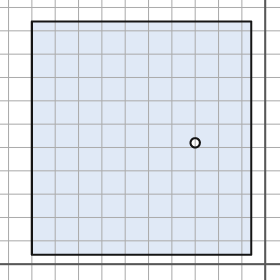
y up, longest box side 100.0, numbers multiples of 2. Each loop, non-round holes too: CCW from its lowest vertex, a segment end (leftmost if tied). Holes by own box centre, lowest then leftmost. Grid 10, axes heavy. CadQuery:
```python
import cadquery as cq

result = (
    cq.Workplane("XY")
    .moveTo(-100.0, 4.0)
    .lineTo(-6.0, 4.0)
    .lineTo(-6.0, 104.0)
    .lineTo(-100.0, 104.0)
    .close()
    .moveTo(-30.0, 52.0)
    .circle(2.0)
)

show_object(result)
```